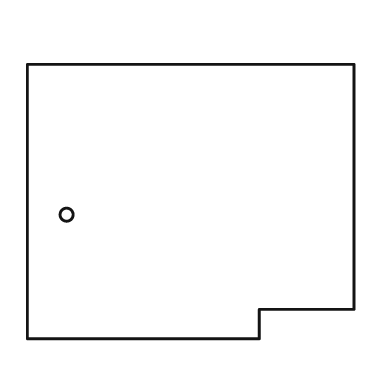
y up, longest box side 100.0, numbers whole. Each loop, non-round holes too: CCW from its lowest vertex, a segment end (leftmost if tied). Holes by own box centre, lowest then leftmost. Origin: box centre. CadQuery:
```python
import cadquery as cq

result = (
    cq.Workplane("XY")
    .moveTo(-50.0, -42.0)
    .lineTo(21.0, -42.0)
    .lineTo(21.0, -33.0)
    .lineTo(50.0, -33.0)
    .lineTo(50.0, 42.0)
    .lineTo(-50.0, 42.0)
    .close()
    .moveTo(-38.0, -4.0)
    .circle(2.0)
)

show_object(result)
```